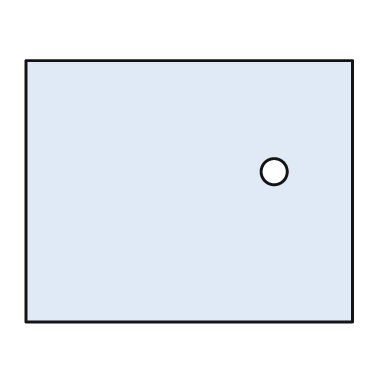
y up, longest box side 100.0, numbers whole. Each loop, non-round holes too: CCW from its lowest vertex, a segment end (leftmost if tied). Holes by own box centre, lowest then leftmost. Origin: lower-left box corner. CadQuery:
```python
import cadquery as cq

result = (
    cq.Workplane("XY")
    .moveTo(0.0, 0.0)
    .lineTo(100.0, 0.0)
    .lineTo(100.0, 80.0)
    .lineTo(0.0, 80.0)
    .close()
    .moveTo(76.0, 46.0)
    .circle(4.0)
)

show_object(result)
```